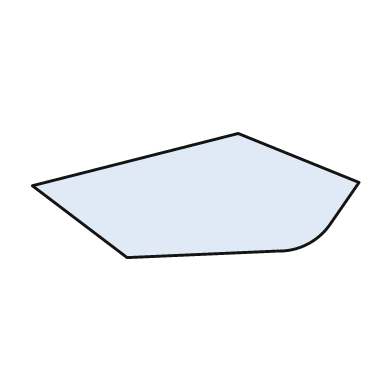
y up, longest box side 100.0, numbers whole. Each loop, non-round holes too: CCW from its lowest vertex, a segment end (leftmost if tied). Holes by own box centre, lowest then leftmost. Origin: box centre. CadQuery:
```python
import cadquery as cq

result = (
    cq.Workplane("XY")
    .moveTo(-21.0, -19.0)
    .lineTo(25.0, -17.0)
    .threePointArc((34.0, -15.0), (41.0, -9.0))
    .lineTo(50.0, 4.0)
    .lineTo(13.0, 19.0)
    .lineTo(-50.0, 3.0)
    .close()
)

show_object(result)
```